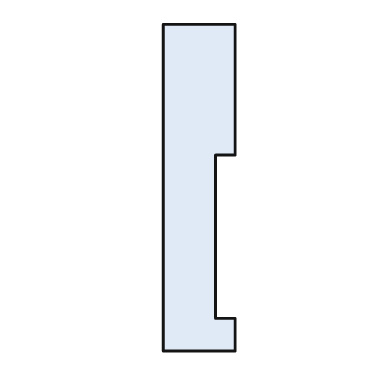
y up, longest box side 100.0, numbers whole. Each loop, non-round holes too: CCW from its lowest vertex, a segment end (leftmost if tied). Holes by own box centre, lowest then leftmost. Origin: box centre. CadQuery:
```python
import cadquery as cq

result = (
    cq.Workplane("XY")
    .moveTo(-11.0, -50.0)
    .lineTo(11.0, -50.0)
    .lineTo(11.0, -40.0)
    .lineTo(5.0, -40.0)
    .lineTo(5.0, 10.0)
    .lineTo(11.0, 10.0)
    .lineTo(11.0, 50.0)
    .lineTo(-11.0, 50.0)
    .close()
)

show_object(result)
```